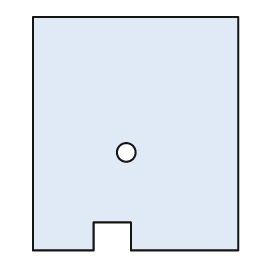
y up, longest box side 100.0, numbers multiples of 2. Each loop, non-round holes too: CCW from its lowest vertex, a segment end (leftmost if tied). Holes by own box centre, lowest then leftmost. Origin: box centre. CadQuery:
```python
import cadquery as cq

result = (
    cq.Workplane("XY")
    .moveTo(-44.0, -50.0)
    .lineTo(-18.0, -50.0)
    .lineTo(-18.0, -38.0)
    .lineTo(-2.0, -38.0)
    .lineTo(-2.0, -50.0)
    .lineTo(44.0, -50.0)
    .lineTo(44.0, 50.0)
    .lineTo(-44.0, 50.0)
    .close()
    .moveTo(-4.0, -8.0)
    .circle(4.0)
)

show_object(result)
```